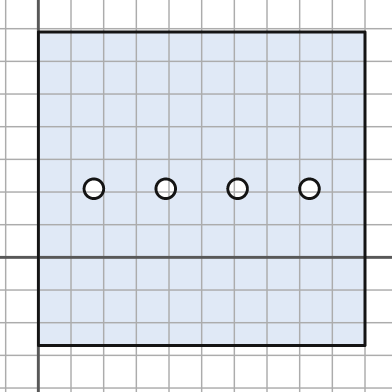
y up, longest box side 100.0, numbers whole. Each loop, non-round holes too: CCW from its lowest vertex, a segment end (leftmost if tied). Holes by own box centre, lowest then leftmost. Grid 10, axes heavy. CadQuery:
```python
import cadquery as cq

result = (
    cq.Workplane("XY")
    .moveTo(0.0, -27.0)
    .lineTo(100.0, -27.0)
    .lineTo(100.0, 69.0)
    .lineTo(0.0, 69.0)
    .close()
    .moveTo(17.0, 21.0)
    .circle(3.0)
    .moveTo(39.0, 21.0)
    .circle(3.0)
    .moveTo(61.0, 21.0)
    .circle(3.0)
    .moveTo(83.0, 21.0)
    .circle(3.0)
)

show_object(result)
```